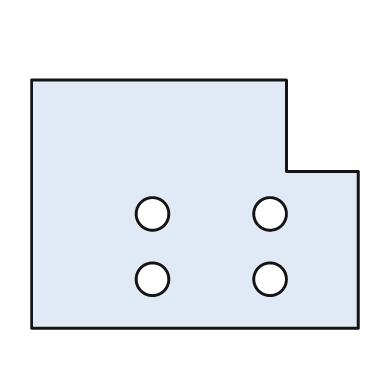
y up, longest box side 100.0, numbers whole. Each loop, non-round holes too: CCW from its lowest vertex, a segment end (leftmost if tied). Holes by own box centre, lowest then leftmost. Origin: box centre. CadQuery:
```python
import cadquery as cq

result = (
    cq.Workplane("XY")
    .moveTo(-50.0, -38.0)
    .lineTo(50.0, -38.0)
    .lineTo(50.0, 10.0)
    .lineTo(28.0, 10.0)
    .lineTo(28.0, 38.0)
    .lineTo(-50.0, 38.0)
    .close()
    .moveTo(-13.0, -23.0)
    .circle(5.0)
    .moveTo(23.0, -23.0)
    .circle(5.0)
    .moveTo(-13.0, -3.0)
    .circle(5.0)
    .moveTo(23.0, -3.0)
    .circle(5.0)
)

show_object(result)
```